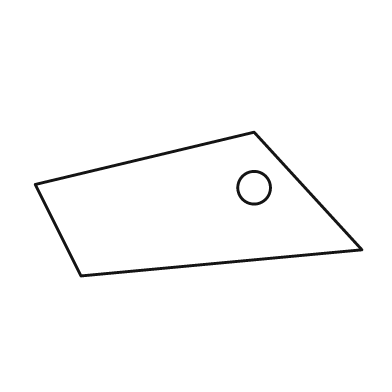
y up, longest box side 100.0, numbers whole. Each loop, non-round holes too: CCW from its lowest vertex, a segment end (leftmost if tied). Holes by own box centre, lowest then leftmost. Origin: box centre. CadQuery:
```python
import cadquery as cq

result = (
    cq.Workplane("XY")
    .moveTo(-36.0, -22.0)
    .lineTo(50.0, -14.0)
    .lineTo(17.0, 22.0)
    .lineTo(-50.0, 6.0)
    .close()
    .moveTo(17.0, 5.0)
    .circle(5.0)
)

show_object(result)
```